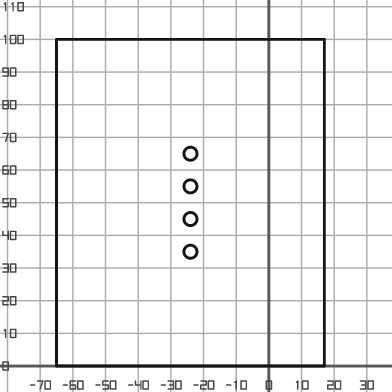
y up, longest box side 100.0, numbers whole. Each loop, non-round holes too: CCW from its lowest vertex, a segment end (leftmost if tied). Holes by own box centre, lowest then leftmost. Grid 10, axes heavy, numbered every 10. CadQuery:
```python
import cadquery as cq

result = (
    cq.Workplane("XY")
    .moveTo(-65.0, 0.0)
    .lineTo(17.0, 0.0)
    .lineTo(17.0, 100.0)
    .lineTo(-65.0, 100.0)
    .close()
    .moveTo(-24.0, 35.0)
    .circle(2.0)
    .moveTo(-24.0, 45.0)
    .circle(2.0)
    .moveTo(-24.0, 55.0)
    .circle(2.0)
    .moveTo(-24.0, 65.0)
    .circle(2.0)
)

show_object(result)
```